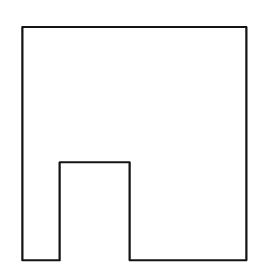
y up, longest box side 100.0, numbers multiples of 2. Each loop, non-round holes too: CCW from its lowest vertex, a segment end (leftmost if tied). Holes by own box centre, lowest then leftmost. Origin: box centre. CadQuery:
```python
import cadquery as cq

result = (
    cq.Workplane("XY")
    .moveTo(-48.0, -50.0)
    .lineTo(-32.0, -50.0)
    .lineTo(-32.0, -8.0)
    .lineTo(-2.0, -8.0)
    .lineTo(-2.0, -50.0)
    .lineTo(48.0, -50.0)
    .lineTo(48.0, 50.0)
    .lineTo(-48.0, 50.0)
    .close()
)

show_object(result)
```